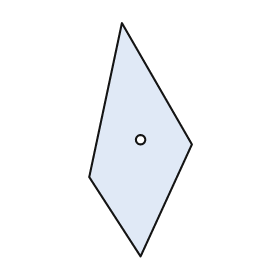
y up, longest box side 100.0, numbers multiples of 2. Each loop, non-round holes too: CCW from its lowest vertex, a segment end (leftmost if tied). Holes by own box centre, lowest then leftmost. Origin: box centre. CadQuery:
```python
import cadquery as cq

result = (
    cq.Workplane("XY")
    .moveTo(0.0, -50.0)
    .lineTo(22.0, -2.0)
    .lineTo(-8.0, 50.0)
    .lineTo(-22.0, -16.0)
    .close()
    .moveTo(0.0, 0.0)
    .circle(2.0)
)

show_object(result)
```